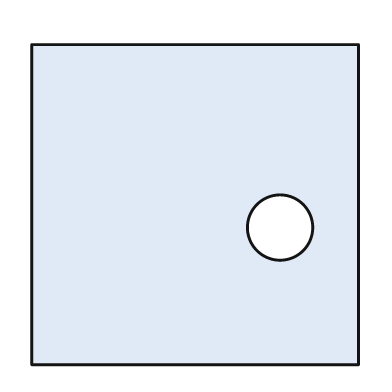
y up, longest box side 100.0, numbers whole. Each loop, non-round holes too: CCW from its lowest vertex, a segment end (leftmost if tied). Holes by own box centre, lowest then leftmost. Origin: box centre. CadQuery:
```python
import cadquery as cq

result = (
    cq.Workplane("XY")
    .moveTo(-50.0, -49.0)
    .lineTo(50.0, -49.0)
    .lineTo(50.0, 49.0)
    .lineTo(-50.0, 49.0)
    .close()
    .moveTo(26.0, -7.0)
    .circle(10.0)
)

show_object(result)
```